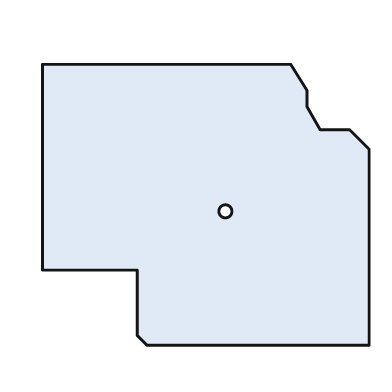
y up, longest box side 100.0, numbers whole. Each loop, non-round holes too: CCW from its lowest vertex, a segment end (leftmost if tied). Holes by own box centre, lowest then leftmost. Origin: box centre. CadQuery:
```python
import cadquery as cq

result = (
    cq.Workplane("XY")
    .moveTo(-18.0, -43.0)
    .lineTo(50.0, -43.0)
    .lineTo(50.0, 17.0)
    .lineTo(44.0, 23.0)
    .lineTo(35.0, 23.0)
    .lineTo(31.0, 30.0)
    .lineTo(31.0, 35.0)
    .lineTo(26.0, 43.0)
    .lineTo(-50.0, 43.0)
    .lineTo(-50.0, -20.0)
    .lineTo(-21.0, -20.0)
    .lineTo(-21.0, -40.0)
    .close()
    .moveTo(6.0, -2.0)
    .circle(2.0)
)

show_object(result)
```